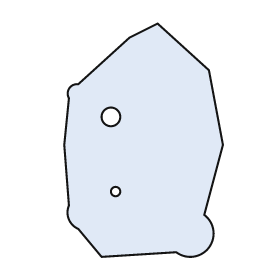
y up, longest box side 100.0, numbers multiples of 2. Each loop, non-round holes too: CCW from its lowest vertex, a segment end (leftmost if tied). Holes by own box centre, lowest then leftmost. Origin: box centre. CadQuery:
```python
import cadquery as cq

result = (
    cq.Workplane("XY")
    .moveTo(-18.0, -50.0)
    .lineTo(14.0, -48.0)
    .threePointArc((28.0, -46.0), (26.0, -32.0))
    .lineTo(34.0, -2.0)
    .lineTo(28.0, 30.0)
    .lineTo(6.0, 50.0)
    .lineTo(-6.0, 44.0)
    .lineTo(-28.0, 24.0)
    .threePointArc((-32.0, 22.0), (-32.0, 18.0))
    .lineTo(-34.0, -2.0)
    .lineTo(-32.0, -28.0)
    .threePointArc((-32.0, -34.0), (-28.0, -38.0))
    .close()
    .moveTo(-12.0, -22.0)
    .circle(2.0)
    .moveTo(-14.0, 10.0)
    .circle(4.0)
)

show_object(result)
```